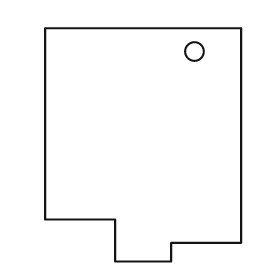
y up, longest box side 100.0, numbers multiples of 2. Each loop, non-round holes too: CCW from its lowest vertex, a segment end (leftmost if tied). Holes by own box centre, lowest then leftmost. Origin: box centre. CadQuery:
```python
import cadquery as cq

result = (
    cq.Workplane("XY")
    .moveTo(-12.0, -50.0)
    .lineTo(12.0, -50.0)
    .lineTo(12.0, -42.0)
    .lineTo(42.0, -42.0)
    .lineTo(42.0, 50.0)
    .lineTo(-42.0, 50.0)
    .lineTo(-42.0, -32.0)
    .lineTo(-12.0, -32.0)
    .close()
    .moveTo(22.0, 40.0)
    .circle(4.0)
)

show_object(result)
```